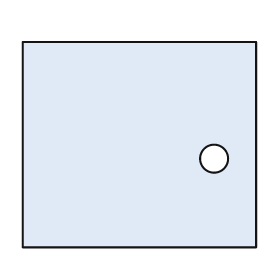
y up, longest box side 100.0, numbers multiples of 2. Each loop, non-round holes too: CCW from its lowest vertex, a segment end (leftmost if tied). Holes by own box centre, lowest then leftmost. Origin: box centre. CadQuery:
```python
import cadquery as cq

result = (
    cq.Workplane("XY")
    .moveTo(-50.0, -44.0)
    .lineTo(50.0, -44.0)
    .lineTo(50.0, 44.0)
    .lineTo(-50.0, 44.0)
    .close()
    .moveTo(32.0, -6.0)
    .circle(6.0)
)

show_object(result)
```